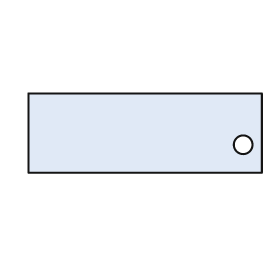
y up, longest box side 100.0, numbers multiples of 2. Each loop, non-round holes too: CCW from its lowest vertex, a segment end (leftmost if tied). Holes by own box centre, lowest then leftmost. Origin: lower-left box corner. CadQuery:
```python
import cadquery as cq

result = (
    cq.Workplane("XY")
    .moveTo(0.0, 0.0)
    .lineTo(100.0, 0.0)
    .lineTo(100.0, 34.0)
    .lineTo(0.0, 34.0)
    .close()
    .moveTo(92.0, 12.0)
    .circle(4.0)
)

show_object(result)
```